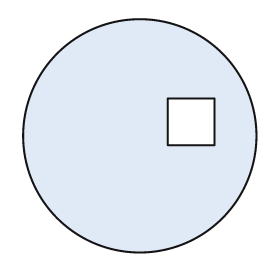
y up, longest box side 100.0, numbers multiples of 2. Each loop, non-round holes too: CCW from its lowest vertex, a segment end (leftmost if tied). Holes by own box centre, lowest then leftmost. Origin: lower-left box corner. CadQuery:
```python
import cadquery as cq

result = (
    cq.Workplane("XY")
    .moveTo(50.0, 50.0)
    .circle(50.0)
    .moveTo(62.0, 46.0)
    .lineTo(82.0, 46.0)
    .lineTo(82.0, 66.0)
    .lineTo(62.0, 66.0)
    .close()
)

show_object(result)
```